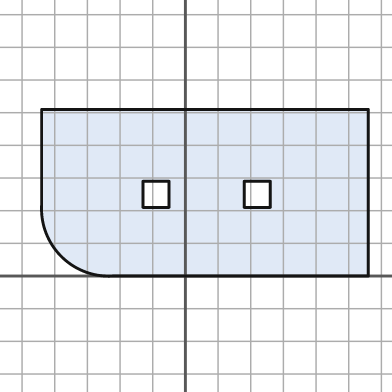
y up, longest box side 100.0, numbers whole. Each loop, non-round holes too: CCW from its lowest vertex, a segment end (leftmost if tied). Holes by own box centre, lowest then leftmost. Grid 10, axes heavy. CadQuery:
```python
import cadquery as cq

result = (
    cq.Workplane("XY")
    .moveTo(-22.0, 0.0)
    .lineTo(56.0, 0.0)
    .lineTo(56.0, 51.0)
    .lineTo(-44.0, 51.0)
    .lineTo(-44.0, 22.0)
    .threePointArc((-38.0, 6.0), (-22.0, 0.0))
    .close()
    .moveTo(-13.0, 21.0)
    .lineTo(-5.0, 21.0)
    .lineTo(-5.0, 29.0)
    .lineTo(-13.0, 29.0)
    .close()
    .moveTo(18.0, 21.0)
    .lineTo(26.0, 21.0)
    .lineTo(26.0, 29.0)
    .lineTo(18.0, 29.0)
    .close()
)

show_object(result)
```